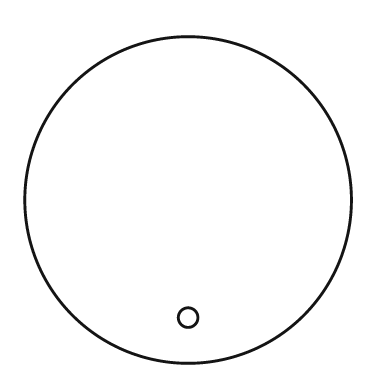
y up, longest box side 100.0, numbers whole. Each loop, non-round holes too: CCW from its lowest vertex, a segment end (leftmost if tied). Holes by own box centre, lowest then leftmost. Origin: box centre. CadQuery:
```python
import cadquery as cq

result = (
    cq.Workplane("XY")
    .moveTo(0.0, 0.0)
    .circle(50.0)
    .moveTo(0.0, -36.0)
    .circle(3.0)
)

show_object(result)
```